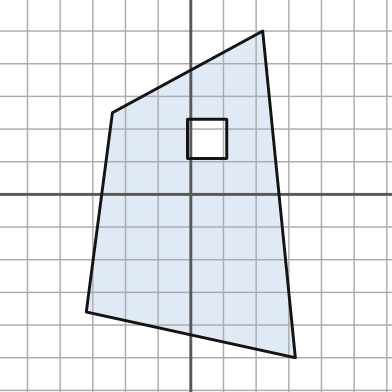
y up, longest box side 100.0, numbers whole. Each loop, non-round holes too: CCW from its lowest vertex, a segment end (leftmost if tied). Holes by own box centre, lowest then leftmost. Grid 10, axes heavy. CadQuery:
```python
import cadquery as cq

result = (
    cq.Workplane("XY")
    .moveTo(32.0, -50.0)
    .lineTo(22.0, 50.0)
    .lineTo(-24.0, 25.0)
    .lineTo(-32.0, -36.0)
    .close()
    .moveTo(-1.0, 11.0)
    .lineTo(11.0, 11.0)
    .lineTo(11.0, 23.0)
    .lineTo(-1.0, 23.0)
    .close()
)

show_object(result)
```